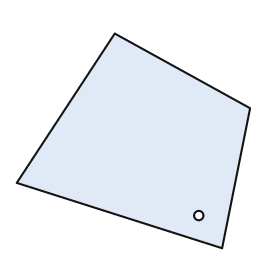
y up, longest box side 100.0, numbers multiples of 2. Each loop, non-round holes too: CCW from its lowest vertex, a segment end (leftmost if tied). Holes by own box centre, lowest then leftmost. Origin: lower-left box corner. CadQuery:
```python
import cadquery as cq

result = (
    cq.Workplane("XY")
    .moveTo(88.0, 0.0)
    .lineTo(100.0, 60.0)
    .lineTo(42.0, 92.0)
    .lineTo(0.0, 28.0)
    .close()
    .moveTo(78.0, 14.0)
    .circle(2.0)
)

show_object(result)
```